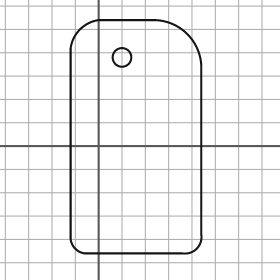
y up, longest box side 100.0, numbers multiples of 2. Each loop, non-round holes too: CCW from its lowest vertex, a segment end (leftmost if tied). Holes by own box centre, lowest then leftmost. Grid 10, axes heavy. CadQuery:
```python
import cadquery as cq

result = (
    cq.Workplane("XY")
    .moveTo(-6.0, -46.0)
    .lineTo(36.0, -46.0)
    .threePointArc((42.0, -44.0), (44.0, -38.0))
    .lineTo(44.0, 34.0)
    .threePointArc((38.0, 48.0), (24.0, 54.0))
    .lineTo(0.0, 54.0)
    .threePointArc((-8.0, 50.0), (-12.0, 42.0))
    .lineTo(-12.0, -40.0)
    .threePointArc((-10.0, -44.0), (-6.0, -46.0))
    .close()
    .moveTo(10.0, 38.0)
    .circle(4.0)
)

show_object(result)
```